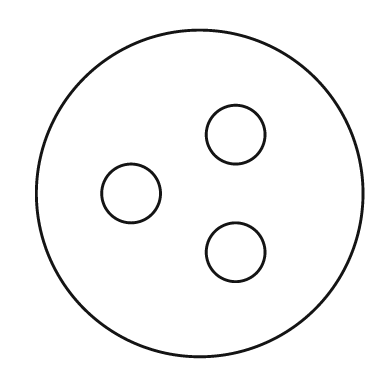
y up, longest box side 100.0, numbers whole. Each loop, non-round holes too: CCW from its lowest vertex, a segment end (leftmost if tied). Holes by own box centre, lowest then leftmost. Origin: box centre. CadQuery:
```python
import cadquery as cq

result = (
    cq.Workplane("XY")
    .moveTo(0.0, 0.0)
    .circle(50.0)
    .moveTo(11.0, -18.0)
    .circle(9.0)
    .moveTo(-21.0, 0.0)
    .circle(9.0)
    .moveTo(11.0, 18.0)
    .circle(9.0)
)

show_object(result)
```